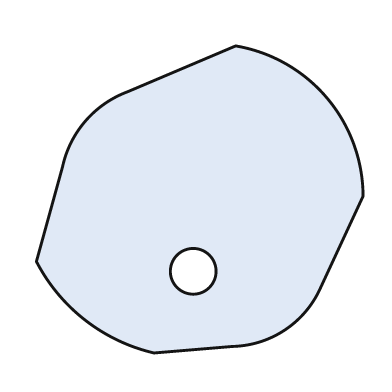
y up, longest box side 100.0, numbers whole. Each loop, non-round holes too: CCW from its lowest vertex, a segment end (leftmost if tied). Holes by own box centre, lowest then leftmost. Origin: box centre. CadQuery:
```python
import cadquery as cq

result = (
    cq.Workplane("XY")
    .moveTo(-14.0, -47.0)
    .lineTo(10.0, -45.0)
    .threePointArc((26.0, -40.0), (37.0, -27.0))
    .lineTo(50.0, 1.0)
    .threePointArc((39.0, 31.0), (11.0, 47.0))
    .lineTo(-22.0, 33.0)
    .threePointArc((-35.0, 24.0), (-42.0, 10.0))
    .lineTo(-50.0, -19.0)
    .threePointArc((-35.0, -37.0), (-14.0, -47.0))
    .close()
    .moveTo(-2.0, -22.0)
    .circle(7.0)
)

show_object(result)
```